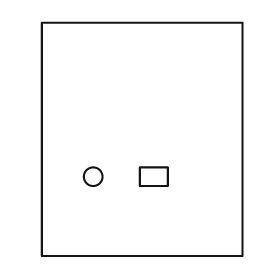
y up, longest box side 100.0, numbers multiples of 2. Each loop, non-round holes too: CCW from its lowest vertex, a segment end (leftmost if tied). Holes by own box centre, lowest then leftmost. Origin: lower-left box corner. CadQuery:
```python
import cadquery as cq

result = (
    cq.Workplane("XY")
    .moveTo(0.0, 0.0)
    .lineTo(86.0, 0.0)
    .lineTo(86.0, 100.0)
    .lineTo(0.0, 100.0)
    .close()
    .moveTo(22.0, 34.0)
    .circle(4.0)
    .moveTo(42.0, 30.0)
    .lineTo(54.0, 30.0)
    .lineTo(54.0, 38.0)
    .lineTo(42.0, 38.0)
    .close()
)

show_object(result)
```